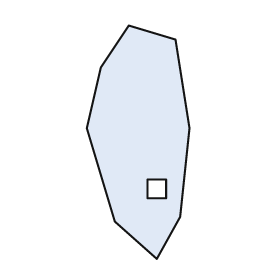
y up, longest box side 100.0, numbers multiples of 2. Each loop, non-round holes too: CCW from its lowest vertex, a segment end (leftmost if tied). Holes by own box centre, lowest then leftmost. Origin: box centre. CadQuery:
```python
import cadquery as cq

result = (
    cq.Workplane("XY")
    .moveTo(8.0, -50.0)
    .lineTo(18.0, -32.0)
    .lineTo(22.0, 6.0)
    .lineTo(16.0, 44.0)
    .lineTo(-4.0, 50.0)
    .lineTo(-16.0, 32.0)
    .lineTo(-22.0, 6.0)
    .lineTo(-10.0, -34.0)
    .close()
    .moveTo(4.0, -24.0)
    .lineTo(12.0, -24.0)
    .lineTo(12.0, -16.0)
    .lineTo(4.0, -16.0)
    .close()
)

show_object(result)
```